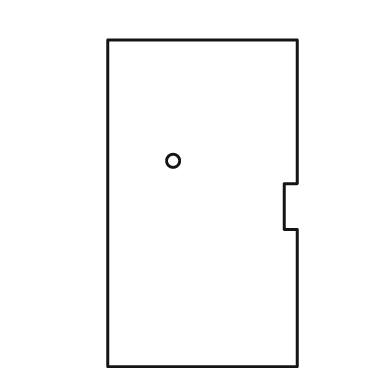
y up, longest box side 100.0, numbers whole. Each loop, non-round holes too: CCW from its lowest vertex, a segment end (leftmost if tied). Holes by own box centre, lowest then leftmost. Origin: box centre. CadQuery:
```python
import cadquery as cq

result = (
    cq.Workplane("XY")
    .moveTo(-29.0, -50.0)
    .lineTo(29.0, -50.0)
    .lineTo(29.0, -8.0)
    .lineTo(25.0, -8.0)
    .lineTo(25.0, 6.0)
    .lineTo(29.0, 6.0)
    .lineTo(29.0, 50.0)
    .lineTo(-29.0, 50.0)
    .close()
    .moveTo(-9.0, 13.0)
    .circle(2.0)
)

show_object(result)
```